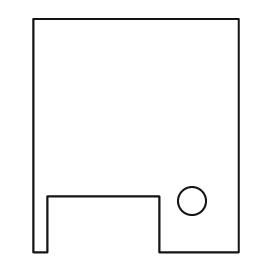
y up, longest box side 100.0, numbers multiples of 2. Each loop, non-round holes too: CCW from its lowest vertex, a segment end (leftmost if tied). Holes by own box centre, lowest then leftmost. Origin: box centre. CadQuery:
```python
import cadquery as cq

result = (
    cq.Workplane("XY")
    .moveTo(-44.0, -50.0)
    .lineTo(-38.0, -50.0)
    .lineTo(-38.0, -26.0)
    .lineTo(10.0, -26.0)
    .lineTo(10.0, -50.0)
    .lineTo(44.0, -50.0)
    .lineTo(44.0, 50.0)
    .lineTo(-44.0, 50.0)
    .close()
    .moveTo(24.0, -28.0)
    .circle(6.0)
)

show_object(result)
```